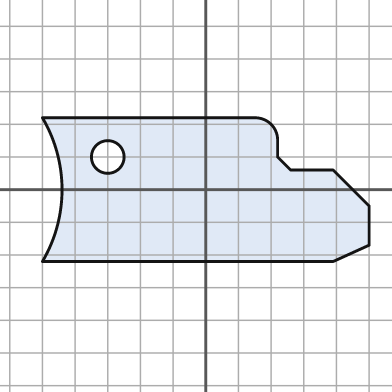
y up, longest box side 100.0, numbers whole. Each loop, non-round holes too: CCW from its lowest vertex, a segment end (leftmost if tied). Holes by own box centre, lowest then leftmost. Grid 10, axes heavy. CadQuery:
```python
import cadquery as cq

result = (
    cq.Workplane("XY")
    .moveTo(-50.0, -22.0)
    .lineTo(39.0, -22.0)
    .lineTo(50.0, -17.0)
    .lineTo(50.0, -5.0)
    .lineTo(39.0, 6.0)
    .lineTo(26.0, 6.0)
    .lineTo(22.0, 10.0)
    .lineTo(22.0, 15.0)
    .threePointArc((20.0, 20.0), (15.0, 22.0))
    .lineTo(-50.0, 22.0)
    .threePointArc((-44.0, 0.0), (-50.0, -22.0))
    .close()
    .moveTo(-30.0, 10.0)
    .circle(5.0)
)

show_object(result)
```